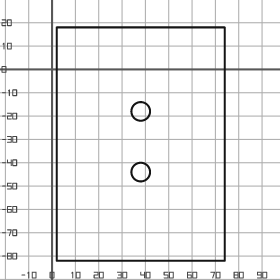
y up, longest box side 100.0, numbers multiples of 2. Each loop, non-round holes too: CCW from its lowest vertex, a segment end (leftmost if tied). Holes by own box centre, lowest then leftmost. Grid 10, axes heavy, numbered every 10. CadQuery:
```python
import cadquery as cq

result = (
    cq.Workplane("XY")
    .moveTo(2.0, -82.0)
    .lineTo(74.0, -82.0)
    .lineTo(74.0, 18.0)
    .lineTo(2.0, 18.0)
    .close()
    .moveTo(38.0, -44.0)
    .circle(4.0)
    .moveTo(38.0, -18.0)
    .circle(4.0)
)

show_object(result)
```